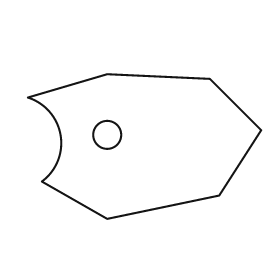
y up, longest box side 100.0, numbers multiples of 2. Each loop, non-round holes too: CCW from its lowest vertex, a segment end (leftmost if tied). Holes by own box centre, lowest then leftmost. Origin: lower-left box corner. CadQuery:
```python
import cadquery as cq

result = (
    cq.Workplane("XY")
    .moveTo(34.0, 0.0)
    .lineTo(82.0, 10.0)
    .lineTo(100.0, 38.0)
    .lineTo(78.0, 60.0)
    .lineTo(34.0, 62.0)
    .lineTo(0.0, 52.0)
    .threePointArc((14.0, 36.0), (6.0, 16.0))
    .close()
    .moveTo(34.0, 36.0)
    .circle(6.0)
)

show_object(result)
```